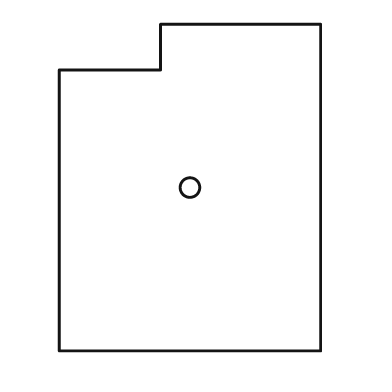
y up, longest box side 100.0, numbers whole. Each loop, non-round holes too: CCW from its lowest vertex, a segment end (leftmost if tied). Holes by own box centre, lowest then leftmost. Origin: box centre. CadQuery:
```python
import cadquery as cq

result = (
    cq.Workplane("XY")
    .moveTo(-40.0, -50.0)
    .lineTo(40.0, -50.0)
    .lineTo(40.0, 50.0)
    .lineTo(-9.0, 50.0)
    .lineTo(-9.0, 36.0)
    .lineTo(-40.0, 36.0)
    .close()
    .moveTo(0.0, 0.0)
    .circle(3.0)
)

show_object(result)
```